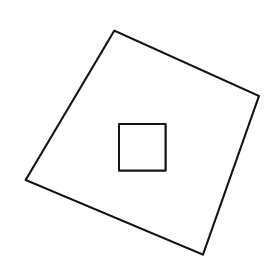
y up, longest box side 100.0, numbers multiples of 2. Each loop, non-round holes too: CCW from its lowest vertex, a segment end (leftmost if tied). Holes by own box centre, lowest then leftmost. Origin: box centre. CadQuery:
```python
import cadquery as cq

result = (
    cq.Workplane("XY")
    .moveTo(26.0, -48.0)
    .lineTo(50.0, 20.0)
    .lineTo(-12.0, 48.0)
    .lineTo(-50.0, -16.0)
    .close()
    .moveTo(-10.0, -12.0)
    .lineTo(10.0, -12.0)
    .lineTo(10.0, 8.0)
    .lineTo(-10.0, 8.0)
    .close()
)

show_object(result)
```